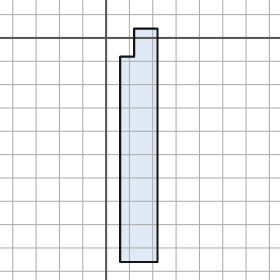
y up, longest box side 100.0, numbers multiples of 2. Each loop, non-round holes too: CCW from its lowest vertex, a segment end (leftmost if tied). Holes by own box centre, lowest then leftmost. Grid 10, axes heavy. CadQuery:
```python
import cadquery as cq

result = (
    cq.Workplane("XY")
    .moveTo(6.0, -96.0)
    .lineTo(22.0, -96.0)
    .lineTo(22.0, 4.0)
    .lineTo(12.0, 4.0)
    .lineTo(12.0, -8.0)
    .lineTo(6.0, -8.0)
    .close()
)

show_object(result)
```